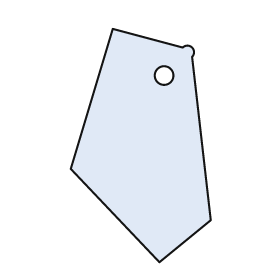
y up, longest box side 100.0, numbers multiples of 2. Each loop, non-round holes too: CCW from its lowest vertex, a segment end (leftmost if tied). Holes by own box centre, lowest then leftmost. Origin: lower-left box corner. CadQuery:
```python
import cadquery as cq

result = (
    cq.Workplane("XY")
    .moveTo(38.0, 0.0)
    .lineTo(60.0, 18.0)
    .lineTo(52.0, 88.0)
    .threePointArc((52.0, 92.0), (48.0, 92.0))
    .lineTo(18.0, 100.0)
    .lineTo(0.0, 40.0)
    .close()
    .moveTo(40.0, 80.0)
    .circle(4.0)
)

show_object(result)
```